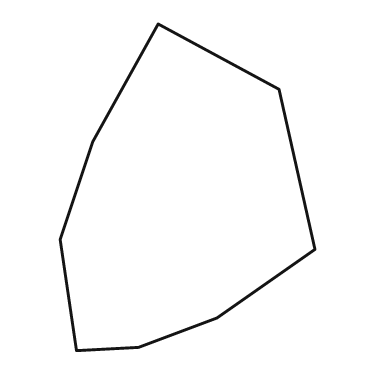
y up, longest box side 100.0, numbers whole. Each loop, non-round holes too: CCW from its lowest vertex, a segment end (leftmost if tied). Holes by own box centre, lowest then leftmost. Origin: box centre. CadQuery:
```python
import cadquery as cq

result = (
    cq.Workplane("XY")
    .moveTo(-34.0, -50.0)
    .lineTo(-15.0, -49.0)
    .lineTo(9.0, -40.0)
    .lineTo(39.0, -19.0)
    .lineTo(28.0, 30.0)
    .lineTo(-9.0, 50.0)
    .lineTo(-29.0, 14.0)
    .lineTo(-39.0, -16.0)
    .close()
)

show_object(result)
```